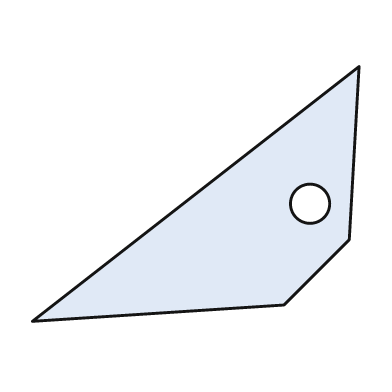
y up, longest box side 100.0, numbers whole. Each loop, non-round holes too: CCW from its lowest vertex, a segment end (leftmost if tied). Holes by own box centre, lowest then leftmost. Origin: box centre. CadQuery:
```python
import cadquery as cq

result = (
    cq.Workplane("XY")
    .moveTo(-50.0, -39.0)
    .lineTo(27.0, -34.0)
    .lineTo(47.0, -14.0)
    .lineTo(50.0, 39.0)
    .close()
    .moveTo(35.0, -3.0)
    .circle(6.0)
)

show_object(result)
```